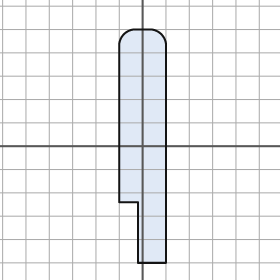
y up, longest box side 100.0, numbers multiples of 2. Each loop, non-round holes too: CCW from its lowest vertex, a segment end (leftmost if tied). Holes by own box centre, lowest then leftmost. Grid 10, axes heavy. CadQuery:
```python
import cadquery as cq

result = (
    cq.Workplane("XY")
    .moveTo(-2.0, -50.0)
    .lineTo(10.0, -50.0)
    .lineTo(10.0, 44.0)
    .threePointArc((8.0, 48.0), (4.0, 50.0))
    .lineTo(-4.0, 50.0)
    .threePointArc((-8.0, 48.0), (-10.0, 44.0))
    .lineTo(-10.0, -24.0)
    .lineTo(-2.0, -24.0)
    .close()
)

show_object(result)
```